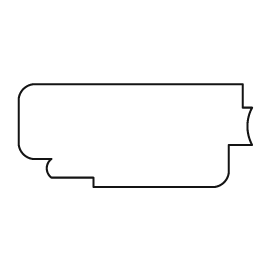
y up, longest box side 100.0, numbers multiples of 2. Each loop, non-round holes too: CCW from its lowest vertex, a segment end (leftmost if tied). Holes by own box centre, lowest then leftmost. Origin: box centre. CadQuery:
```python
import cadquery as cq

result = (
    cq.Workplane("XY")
    .moveTo(-18.0, -22.0)
    .lineTo(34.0, -22.0)
    .threePointArc((38.0, -20.0), (40.0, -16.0))
    .lineTo(40.0, -4.0)
    .lineTo(50.0, -4.0)
    .threePointArc((48.0, 4.0), (50.0, 12.0))
    .lineTo(46.0, 12.0)
    .lineTo(46.0, 22.0)
    .lineTo(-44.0, 22.0)
    .threePointArc((-48.0, 20.0), (-50.0, 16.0))
    .lineTo(-50.0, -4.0)
    .threePointArc((-48.0, -8.0), (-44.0, -10.0))
    .lineTo(-36.0, -10.0)
    .threePointArc((-38.0, -14.0), (-36.0, -18.0))
    .lineTo(-18.0, -18.0)
    .close()
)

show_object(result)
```